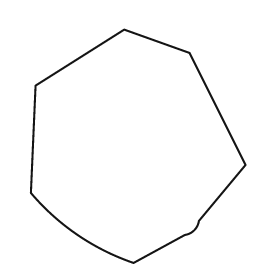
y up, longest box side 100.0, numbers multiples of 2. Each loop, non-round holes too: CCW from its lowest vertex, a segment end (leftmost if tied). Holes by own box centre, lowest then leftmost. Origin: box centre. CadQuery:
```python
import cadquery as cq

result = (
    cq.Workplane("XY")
    .moveTo(-2.0, -50.0)
    .lineTo(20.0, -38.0)
    .threePointArc((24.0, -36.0), (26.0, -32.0))
    .lineTo(46.0, -8.0)
    .lineTo(22.0, 40.0)
    .lineTo(-6.0, 50.0)
    .lineTo(-44.0, 26.0)
    .lineTo(-46.0, -20.0)
    .threePointArc((-26.0, -38.0), (-2.0, -50.0))
    .close()
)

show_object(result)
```